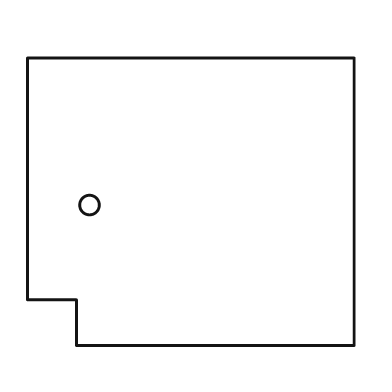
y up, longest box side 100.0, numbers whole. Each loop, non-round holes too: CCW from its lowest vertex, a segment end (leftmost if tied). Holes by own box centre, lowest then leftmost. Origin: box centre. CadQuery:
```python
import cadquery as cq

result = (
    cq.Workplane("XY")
    .moveTo(-35.0, -44.0)
    .lineTo(50.0, -44.0)
    .lineTo(50.0, 44.0)
    .lineTo(-50.0, 44.0)
    .lineTo(-50.0, -30.0)
    .lineTo(-35.0, -30.0)
    .close()
    .moveTo(-31.0, -1.0)
    .circle(3.0)
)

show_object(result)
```